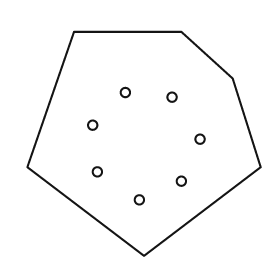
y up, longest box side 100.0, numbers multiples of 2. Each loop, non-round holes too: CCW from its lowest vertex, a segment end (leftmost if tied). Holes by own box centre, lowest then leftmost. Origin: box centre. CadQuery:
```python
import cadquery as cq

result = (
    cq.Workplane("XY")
    .moveTo(0.0, -48.0)
    .lineTo(50.0, -10.0)
    .lineTo(38.0, 28.0)
    .lineTo(16.0, 48.0)
    .lineTo(-30.0, 48.0)
    .lineTo(-50.0, -10.0)
    .close()
    .moveTo(-2.0, -24.0)
    .circle(2.0)
    .moveTo(16.0, -16.0)
    .circle(2.0)
    .moveTo(-20.0, -12.0)
    .circle(2.0)
    .moveTo(24.0, 2.0)
    .circle(2.0)
    .moveTo(-22.0, 8.0)
    .circle(2.0)
    .moveTo(12.0, 20.0)
    .circle(2.0)
    .moveTo(-8.0, 22.0)
    .circle(2.0)
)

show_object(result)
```